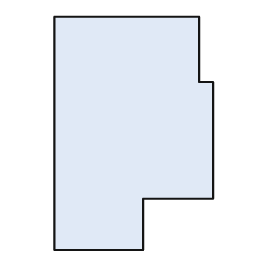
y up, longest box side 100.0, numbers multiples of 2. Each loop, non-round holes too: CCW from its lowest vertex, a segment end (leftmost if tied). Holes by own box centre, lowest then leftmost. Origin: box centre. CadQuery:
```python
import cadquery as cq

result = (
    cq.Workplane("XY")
    .moveTo(-34.0, -50.0)
    .lineTo(4.0, -50.0)
    .lineTo(4.0, -28.0)
    .lineTo(34.0, -28.0)
    .lineTo(34.0, 22.0)
    .lineTo(28.0, 22.0)
    .lineTo(28.0, 50.0)
    .lineTo(-34.0, 50.0)
    .close()
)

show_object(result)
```